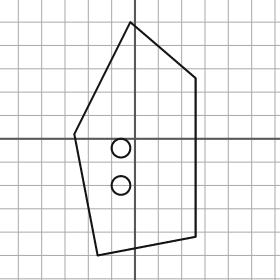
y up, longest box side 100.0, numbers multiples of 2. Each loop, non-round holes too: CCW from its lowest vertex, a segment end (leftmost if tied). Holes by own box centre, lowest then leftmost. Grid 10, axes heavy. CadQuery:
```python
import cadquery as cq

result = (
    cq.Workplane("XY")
    .moveTo(-16.0, -50.0)
    .lineTo(26.0, -42.0)
    .lineTo(26.0, 26.0)
    .lineTo(-2.0, 50.0)
    .lineTo(-26.0, 2.0)
    .close()
    .moveTo(-6.0, -20.0)
    .circle(4.0)
    .moveTo(-6.0, -4.0)
    .circle(4.0)
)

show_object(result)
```